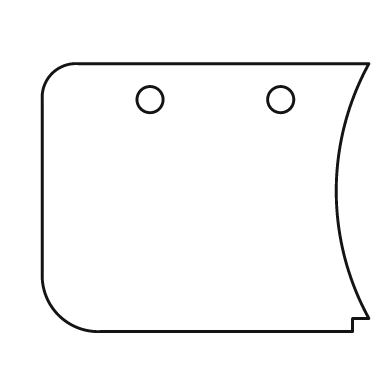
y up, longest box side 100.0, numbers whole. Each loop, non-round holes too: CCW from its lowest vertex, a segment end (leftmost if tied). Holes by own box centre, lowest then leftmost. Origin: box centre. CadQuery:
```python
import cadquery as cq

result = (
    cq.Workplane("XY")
    .moveTo(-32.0, -41.0)
    .lineTo(45.0, -41.0)
    .lineTo(45.0, -37.0)
    .lineTo(50.0, -37.0)
    .threePointArc((40.0, 2.0), (50.0, 41.0))
    .lineTo(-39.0, 41.0)
    .threePointArc((-47.0, 38.0), (-50.0, 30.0))
    .lineTo(-50.0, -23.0)
    .threePointArc((-45.0, -36.0), (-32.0, -41.0))
    .close()
    .moveTo(-17.0, 30.0)
    .circle(4.0)
    .moveTo(23.0, 30.0)
    .circle(4.0)
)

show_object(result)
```